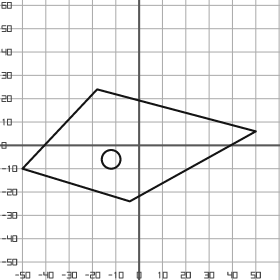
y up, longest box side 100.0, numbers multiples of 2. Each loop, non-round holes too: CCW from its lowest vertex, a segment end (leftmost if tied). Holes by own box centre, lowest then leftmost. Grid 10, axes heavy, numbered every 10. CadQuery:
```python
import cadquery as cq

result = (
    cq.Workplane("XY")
    .moveTo(-4.0, -24.0)
    .lineTo(50.0, 6.0)
    .lineTo(-18.0, 24.0)
    .lineTo(-50.0, -10.0)
    .close()
    .moveTo(-12.0, -6.0)
    .circle(4.0)
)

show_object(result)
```